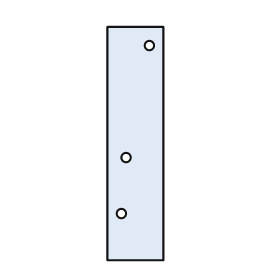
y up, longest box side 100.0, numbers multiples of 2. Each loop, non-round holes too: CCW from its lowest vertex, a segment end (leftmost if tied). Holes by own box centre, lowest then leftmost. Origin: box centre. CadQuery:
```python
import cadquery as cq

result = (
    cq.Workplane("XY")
    .moveTo(-12.0, -50.0)
    .lineTo(12.0, -50.0)
    .lineTo(12.0, 50.0)
    .lineTo(-12.0, 50.0)
    .close()
    .moveTo(-6.0, -30.0)
    .circle(2.0)
    .moveTo(-4.0, -6.0)
    .circle(2.0)
    .moveTo(6.0, 42.0)
    .circle(2.0)
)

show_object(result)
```